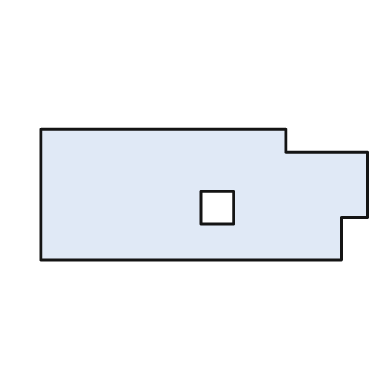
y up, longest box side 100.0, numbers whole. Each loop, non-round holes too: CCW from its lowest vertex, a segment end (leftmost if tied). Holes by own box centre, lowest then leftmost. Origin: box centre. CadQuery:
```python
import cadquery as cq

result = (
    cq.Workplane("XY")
    .moveTo(-50.0, -20.0)
    .lineTo(42.0, -20.0)
    .lineTo(42.0, -7.0)
    .lineTo(50.0, -7.0)
    .lineTo(50.0, 13.0)
    .lineTo(25.0, 13.0)
    .lineTo(25.0, 20.0)
    .lineTo(-50.0, 20.0)
    .close()
    .moveTo(-1.0, -9.0)
    .lineTo(9.0, -9.0)
    .lineTo(9.0, 1.0)
    .lineTo(-1.0, 1.0)
    .close()
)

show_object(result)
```